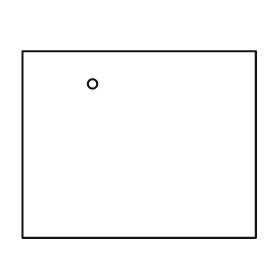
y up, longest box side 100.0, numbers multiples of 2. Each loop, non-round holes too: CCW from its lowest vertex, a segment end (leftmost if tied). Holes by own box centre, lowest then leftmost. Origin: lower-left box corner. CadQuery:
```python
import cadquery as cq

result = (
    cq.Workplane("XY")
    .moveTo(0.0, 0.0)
    .lineTo(100.0, 0.0)
    .lineTo(100.0, 80.0)
    .lineTo(0.0, 80.0)
    .close()
    .moveTo(30.0, 66.0)
    .circle(2.0)
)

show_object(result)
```